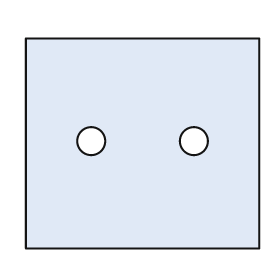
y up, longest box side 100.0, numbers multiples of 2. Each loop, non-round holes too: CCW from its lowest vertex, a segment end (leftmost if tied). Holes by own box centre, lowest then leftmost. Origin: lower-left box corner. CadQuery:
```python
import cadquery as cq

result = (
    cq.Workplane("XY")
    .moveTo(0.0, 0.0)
    .lineTo(100.0, 0.0)
    .lineTo(100.0, 90.0)
    .lineTo(0.0, 90.0)
    .close()
    .moveTo(28.0, 46.0)
    .circle(6.0)
    .moveTo(72.0, 46.0)
    .circle(6.0)
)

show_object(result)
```